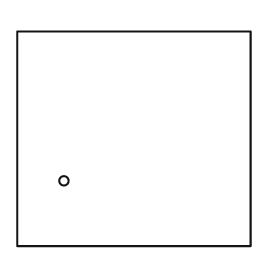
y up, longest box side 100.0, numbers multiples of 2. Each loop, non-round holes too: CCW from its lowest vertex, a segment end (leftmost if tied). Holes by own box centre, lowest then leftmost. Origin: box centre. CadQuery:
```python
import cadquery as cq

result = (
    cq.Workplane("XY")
    .moveTo(-50.0, -46.0)
    .lineTo(50.0, -46.0)
    .lineTo(50.0, 46.0)
    .lineTo(-50.0, 46.0)
    .close()
    .moveTo(-30.0, -18.0)
    .circle(2.0)
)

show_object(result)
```